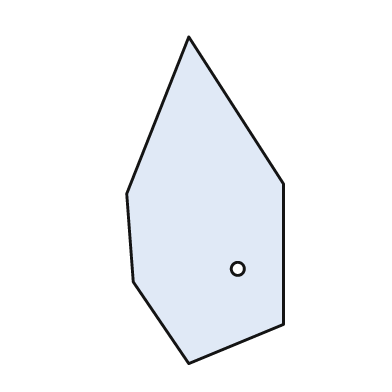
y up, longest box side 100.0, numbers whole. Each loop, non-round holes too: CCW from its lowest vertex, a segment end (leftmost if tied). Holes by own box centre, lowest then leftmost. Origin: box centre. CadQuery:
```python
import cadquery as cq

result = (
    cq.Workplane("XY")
    .moveTo(-5.0, -50.0)
    .lineTo(24.0, -38.0)
    .lineTo(24.0, 5.0)
    .lineTo(-5.0, 50.0)
    .lineTo(-24.0, 2.0)
    .lineTo(-22.0, -25.0)
    .close()
    .moveTo(10.0, -21.0)
    .circle(2.0)
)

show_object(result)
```